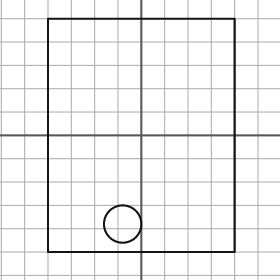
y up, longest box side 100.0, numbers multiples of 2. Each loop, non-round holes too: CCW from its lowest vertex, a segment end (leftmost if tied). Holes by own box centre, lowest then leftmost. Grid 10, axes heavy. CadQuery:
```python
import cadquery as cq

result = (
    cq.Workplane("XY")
    .moveTo(-40.0, -50.0)
    .lineTo(40.0, -50.0)
    .lineTo(40.0, 50.0)
    .lineTo(-40.0, 50.0)
    .close()
    .moveTo(-8.0, -38.0)
    .circle(8.0)
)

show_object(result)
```